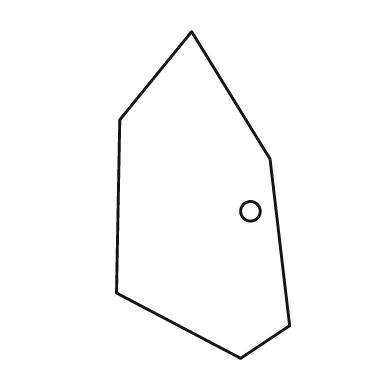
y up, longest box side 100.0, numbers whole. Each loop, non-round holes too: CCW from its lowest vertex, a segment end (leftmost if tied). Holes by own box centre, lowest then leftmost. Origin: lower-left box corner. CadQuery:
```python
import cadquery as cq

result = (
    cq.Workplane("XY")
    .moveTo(38.0, 0.0)
    .lineTo(53.0, 10.0)
    .lineTo(47.0, 61.0)
    .lineTo(23.0, 100.0)
    .lineTo(1.0, 73.0)
    .lineTo(0.0, 20.0)
    .close()
    .moveTo(41.0, 45.0)
    .circle(3.0)
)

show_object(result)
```